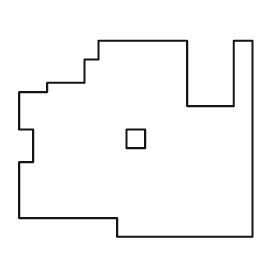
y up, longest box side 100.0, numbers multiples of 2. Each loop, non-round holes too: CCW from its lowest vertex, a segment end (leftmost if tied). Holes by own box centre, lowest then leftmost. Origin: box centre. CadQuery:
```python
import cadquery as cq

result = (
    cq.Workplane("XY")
    .moveTo(-8.0, -42.0)
    .lineTo(50.0, -42.0)
    .lineTo(50.0, 42.0)
    .lineTo(42.0, 42.0)
    .lineTo(42.0, 14.0)
    .lineTo(22.0, 14.0)
    .lineTo(22.0, 42.0)
    .lineTo(-16.0, 42.0)
    .lineTo(-16.0, 34.0)
    .lineTo(-22.0, 34.0)
    .lineTo(-22.0, 24.0)
    .lineTo(-38.0, 24.0)
    .lineTo(-38.0, 20.0)
    .lineTo(-50.0, 20.0)
    .lineTo(-50.0, 4.0)
    .lineTo(-44.0, 4.0)
    .lineTo(-44.0, -10.0)
    .lineTo(-50.0, -10.0)
    .lineTo(-50.0, -34.0)
    .lineTo(-8.0, -34.0)
    .close()
    .moveTo(-4.0, -4.0)
    .lineTo(4.0, -4.0)
    .lineTo(4.0, 4.0)
    .lineTo(-4.0, 4.0)
    .close()
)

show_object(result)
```